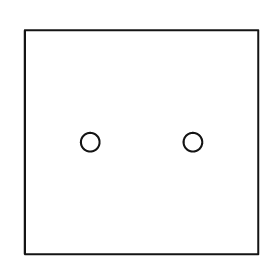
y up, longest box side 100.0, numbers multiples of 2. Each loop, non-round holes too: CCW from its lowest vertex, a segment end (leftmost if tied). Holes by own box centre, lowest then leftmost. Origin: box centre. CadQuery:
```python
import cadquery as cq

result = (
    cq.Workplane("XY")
    .moveTo(-50.0, -48.0)
    .lineTo(50.0, -48.0)
    .lineTo(50.0, 48.0)
    .lineTo(-50.0, 48.0)
    .close()
    .moveTo(-22.0, 0.0)
    .circle(4.0)
    .moveTo(22.0, 0.0)
    .circle(4.0)
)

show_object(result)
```